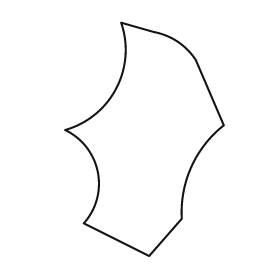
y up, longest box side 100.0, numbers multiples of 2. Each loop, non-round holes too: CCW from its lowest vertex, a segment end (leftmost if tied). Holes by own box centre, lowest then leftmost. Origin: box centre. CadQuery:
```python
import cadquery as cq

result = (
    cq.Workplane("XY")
    .moveTo(2.0, -50.0)
    .lineTo(16.0, -34.0)
    .threePointArc((20.0, -12.0), (34.0, 6.0))
    .lineTo(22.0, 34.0)
    .threePointArc((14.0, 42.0), (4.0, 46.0))
    .lineTo(-10.0, 50.0)
    .threePointArc((-12.0, 22.0), (-34.0, 4.0))
    .threePointArc((-20.0, -14.0), (-26.0, -36.0))
    .close()
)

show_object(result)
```